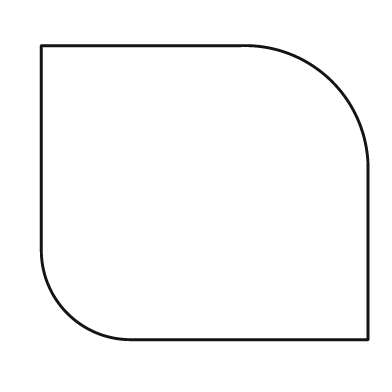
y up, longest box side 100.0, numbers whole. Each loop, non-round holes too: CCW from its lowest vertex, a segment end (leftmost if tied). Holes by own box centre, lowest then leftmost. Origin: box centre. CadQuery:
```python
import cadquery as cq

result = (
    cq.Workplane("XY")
    .moveTo(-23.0, -45.0)
    .lineTo(50.0, -45.0)
    .lineTo(50.0, 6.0)
    .threePointArc((39.0, 34.0), (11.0, 45.0))
    .lineTo(-50.0, 45.0)
    .lineTo(-50.0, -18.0)
    .threePointArc((-42.0, -37.0), (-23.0, -45.0))
    .close()
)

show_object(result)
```